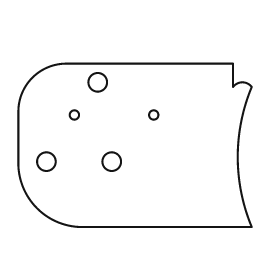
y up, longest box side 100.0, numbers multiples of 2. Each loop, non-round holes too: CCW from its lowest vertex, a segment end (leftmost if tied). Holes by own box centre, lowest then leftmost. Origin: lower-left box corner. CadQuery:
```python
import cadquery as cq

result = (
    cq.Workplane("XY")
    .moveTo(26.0, 0.0)
    .lineTo(100.0, 0.0)
    .threePointArc((94.0, 30.0), (100.0, 60.0))
    .threePointArc((96.0, 62.0), (92.0, 60.0))
    .lineTo(92.0, 70.0)
    .lineTo(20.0, 70.0)
    .threePointArc((6.0, 64.0), (0.0, 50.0))
    .lineTo(0.0, 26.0)
    .threePointArc((8.0, 8.0), (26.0, 0.0))
    .close()
    .moveTo(12.0, 28.0)
    .circle(4.0)
    .moveTo(40.0, 28.0)
    .circle(4.0)
    .moveTo(24.0, 48.0)
    .circle(2.0)
    .moveTo(58.0, 48.0)
    .circle(2.0)
    .moveTo(34.0, 62.0)
    .circle(4.0)
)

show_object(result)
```